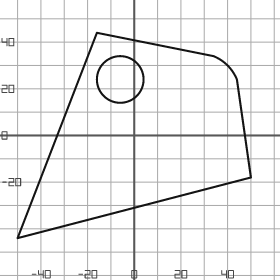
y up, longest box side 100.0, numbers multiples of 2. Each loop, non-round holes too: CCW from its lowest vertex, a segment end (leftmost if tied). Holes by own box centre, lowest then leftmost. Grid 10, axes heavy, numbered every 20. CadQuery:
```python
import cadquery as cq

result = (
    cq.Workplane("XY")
    .moveTo(-50.0, -44.0)
    .lineTo(50.0, -18.0)
    .lineTo(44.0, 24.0)
    .threePointArc((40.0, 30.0), (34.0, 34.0))
    .lineTo(-16.0, 44.0)
    .close()
    .moveTo(-6.0, 24.0)
    .circle(10.0)
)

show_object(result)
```